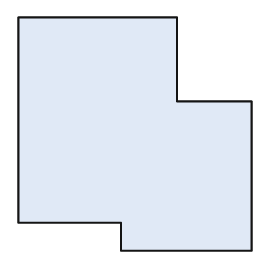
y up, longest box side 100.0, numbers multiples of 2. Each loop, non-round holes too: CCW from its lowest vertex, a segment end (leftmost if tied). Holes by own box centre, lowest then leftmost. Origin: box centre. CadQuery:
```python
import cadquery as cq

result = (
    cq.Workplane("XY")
    .moveTo(-6.0, -50.0)
    .lineTo(50.0, -50.0)
    .lineTo(50.0, 14.0)
    .lineTo(18.0, 14.0)
    .lineTo(18.0, 50.0)
    .lineTo(-50.0, 50.0)
    .lineTo(-50.0, -38.0)
    .lineTo(-6.0, -38.0)
    .close()
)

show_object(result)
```